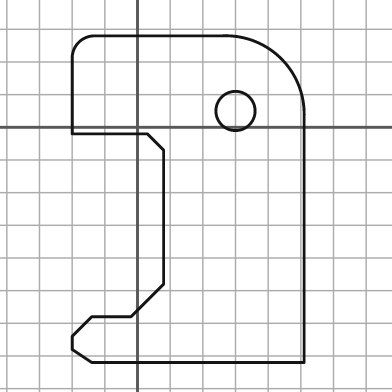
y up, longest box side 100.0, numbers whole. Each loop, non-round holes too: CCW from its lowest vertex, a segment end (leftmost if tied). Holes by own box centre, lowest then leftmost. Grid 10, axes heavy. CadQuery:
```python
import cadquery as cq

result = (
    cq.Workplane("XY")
    .moveTo(-14.0, -72.0)
    .lineTo(51.0, -72.0)
    .lineTo(51.0, 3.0)
    .threePointArc((44.0, 21.0), (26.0, 28.0))
    .lineTo(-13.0, 28.0)
    .threePointArc((-18.0, 26.0), (-20.0, 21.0))
    .lineTo(-20.0, -2.0)
    .lineTo(3.0, -2.0)
    .lineTo(8.0, -7.0)
    .lineTo(8.0, -48.0)
    .lineTo(-2.0, -58.0)
    .lineTo(-14.0, -58.0)
    .lineTo(-20.0, -64.0)
    .lineTo(-20.0, -68.0)
    .close()
    .moveTo(30.0, 5.0)
    .circle(6.0)
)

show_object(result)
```